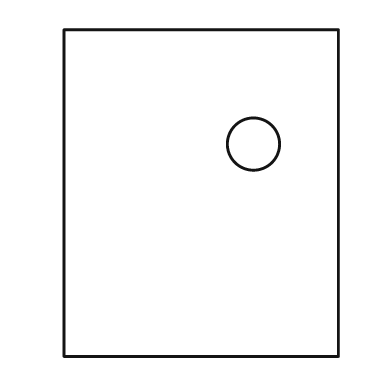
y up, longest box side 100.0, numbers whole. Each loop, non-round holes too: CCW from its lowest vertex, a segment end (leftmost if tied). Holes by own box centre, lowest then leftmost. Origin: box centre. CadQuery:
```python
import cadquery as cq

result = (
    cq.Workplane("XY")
    .moveTo(-42.0, -50.0)
    .lineTo(42.0, -50.0)
    .lineTo(42.0, 50.0)
    .lineTo(-42.0, 50.0)
    .close()
    .moveTo(16.0, 15.0)
    .circle(8.0)
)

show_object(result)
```